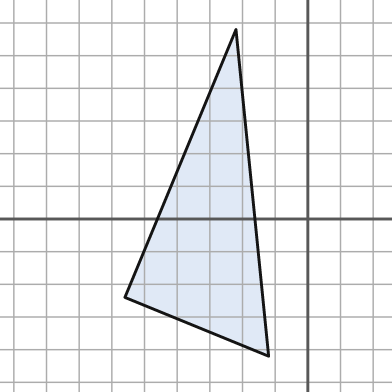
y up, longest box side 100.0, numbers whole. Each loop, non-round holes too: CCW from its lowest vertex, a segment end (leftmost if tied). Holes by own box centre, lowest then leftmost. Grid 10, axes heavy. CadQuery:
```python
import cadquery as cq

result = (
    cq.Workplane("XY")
    .moveTo(-12.0, -42.0)
    .lineTo(-22.0, 58.0)
    .lineTo(-56.0, -24.0)
    .close()
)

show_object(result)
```